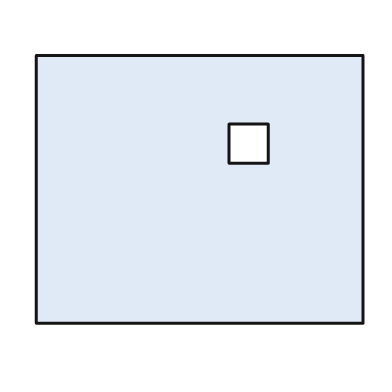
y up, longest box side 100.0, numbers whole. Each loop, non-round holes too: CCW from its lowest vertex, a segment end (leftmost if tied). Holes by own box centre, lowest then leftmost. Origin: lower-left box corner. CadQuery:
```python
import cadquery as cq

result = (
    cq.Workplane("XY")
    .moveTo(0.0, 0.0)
    .lineTo(100.0, 0.0)
    .lineTo(100.0, 82.0)
    .lineTo(0.0, 82.0)
    .close()
    .moveTo(59.0, 49.0)
    .lineTo(71.0, 49.0)
    .lineTo(71.0, 61.0)
    .lineTo(59.0, 61.0)
    .close()
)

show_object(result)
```